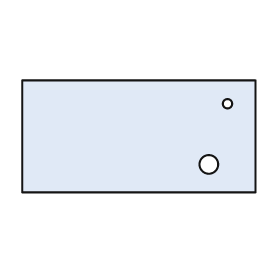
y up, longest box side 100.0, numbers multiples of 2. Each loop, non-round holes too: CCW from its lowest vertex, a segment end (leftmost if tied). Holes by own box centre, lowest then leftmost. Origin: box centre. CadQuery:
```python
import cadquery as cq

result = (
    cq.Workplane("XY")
    .moveTo(-50.0, -24.0)
    .lineTo(50.0, -24.0)
    .lineTo(50.0, 24.0)
    .lineTo(-50.0, 24.0)
    .close()
    .moveTo(30.0, -12.0)
    .circle(4.0)
    .moveTo(38.0, 14.0)
    .circle(2.0)
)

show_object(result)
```